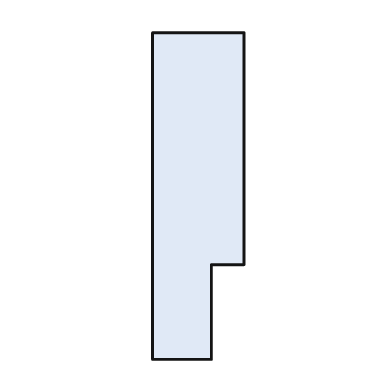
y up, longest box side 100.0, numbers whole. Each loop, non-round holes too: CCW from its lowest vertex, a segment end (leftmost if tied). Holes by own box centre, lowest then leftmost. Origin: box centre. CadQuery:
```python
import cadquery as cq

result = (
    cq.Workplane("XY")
    .moveTo(-14.0, -50.0)
    .lineTo(4.0, -50.0)
    .lineTo(4.0, -21.0)
    .lineTo(14.0, -21.0)
    .lineTo(14.0, 50.0)
    .lineTo(-14.0, 50.0)
    .close()
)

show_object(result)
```